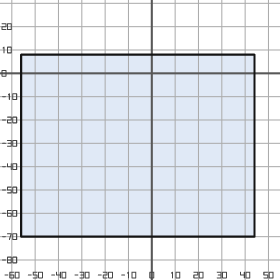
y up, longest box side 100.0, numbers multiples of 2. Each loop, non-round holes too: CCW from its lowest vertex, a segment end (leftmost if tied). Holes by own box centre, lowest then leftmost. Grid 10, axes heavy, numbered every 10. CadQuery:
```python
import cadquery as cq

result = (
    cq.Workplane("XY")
    .moveTo(-56.0, -70.0)
    .lineTo(44.0, -70.0)
    .lineTo(44.0, 8.0)
    .lineTo(-56.0, 8.0)
    .close()
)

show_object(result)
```